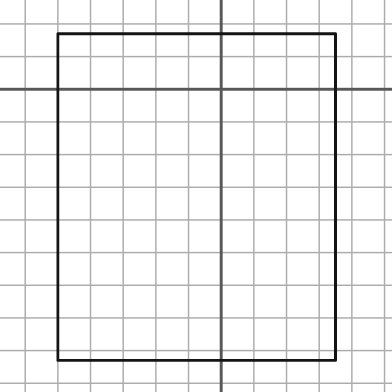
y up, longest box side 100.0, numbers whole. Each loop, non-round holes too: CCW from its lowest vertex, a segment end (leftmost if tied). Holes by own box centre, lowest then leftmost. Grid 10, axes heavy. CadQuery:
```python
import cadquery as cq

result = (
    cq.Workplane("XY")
    .moveTo(-50.0, -83.0)
    .lineTo(35.0, -83.0)
    .lineTo(35.0, 17.0)
    .lineTo(-50.0, 17.0)
    .close()
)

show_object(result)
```